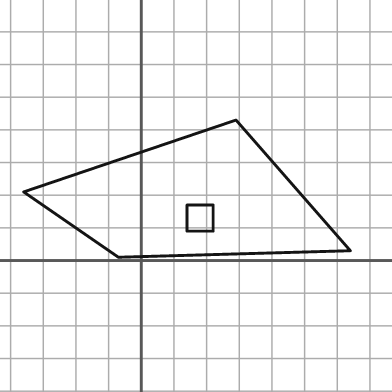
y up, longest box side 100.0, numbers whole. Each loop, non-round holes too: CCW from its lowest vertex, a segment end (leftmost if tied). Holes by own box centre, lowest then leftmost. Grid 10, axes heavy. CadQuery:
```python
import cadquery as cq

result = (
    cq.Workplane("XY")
    .moveTo(-7.0, 1.0)
    .lineTo(64.0, 3.0)
    .lineTo(29.0, 43.0)
    .lineTo(-36.0, 21.0)
    .close()
    .moveTo(14.0, 9.0)
    .lineTo(22.0, 9.0)
    .lineTo(22.0, 17.0)
    .lineTo(14.0, 17.0)
    .close()
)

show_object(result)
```